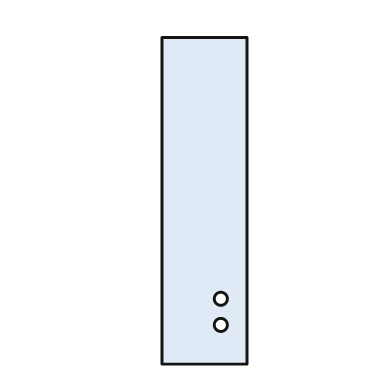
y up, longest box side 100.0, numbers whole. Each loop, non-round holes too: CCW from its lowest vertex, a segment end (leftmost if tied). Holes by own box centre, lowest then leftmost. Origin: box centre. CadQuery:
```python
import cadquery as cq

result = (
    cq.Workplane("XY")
    .moveTo(-13.0, -50.0)
    .lineTo(13.0, -50.0)
    .lineTo(13.0, 50.0)
    .lineTo(-13.0, 50.0)
    .close()
    .moveTo(5.0, -38.0)
    .circle(2.0)
    .moveTo(5.0, -30.0)
    .circle(2.0)
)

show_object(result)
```